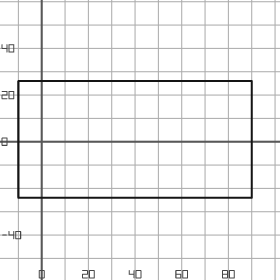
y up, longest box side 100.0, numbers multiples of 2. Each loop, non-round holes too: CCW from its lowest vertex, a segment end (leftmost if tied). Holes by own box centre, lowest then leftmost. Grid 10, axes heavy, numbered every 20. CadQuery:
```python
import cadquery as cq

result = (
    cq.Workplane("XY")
    .moveTo(-10.0, -24.0)
    .lineTo(90.0, -24.0)
    .lineTo(90.0, 26.0)
    .lineTo(-10.0, 26.0)
    .close()
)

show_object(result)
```